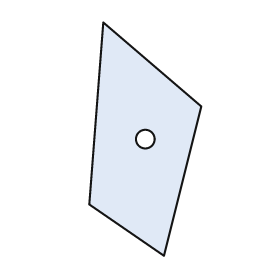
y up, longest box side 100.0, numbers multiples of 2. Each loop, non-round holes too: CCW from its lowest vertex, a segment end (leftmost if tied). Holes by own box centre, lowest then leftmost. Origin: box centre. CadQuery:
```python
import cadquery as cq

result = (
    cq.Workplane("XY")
    .moveTo(8.0, -50.0)
    .lineTo(24.0, 14.0)
    .lineTo(-18.0, 50.0)
    .lineTo(-24.0, -28.0)
    .close()
    .moveTo(0.0, 0.0)
    .circle(4.0)
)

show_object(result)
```